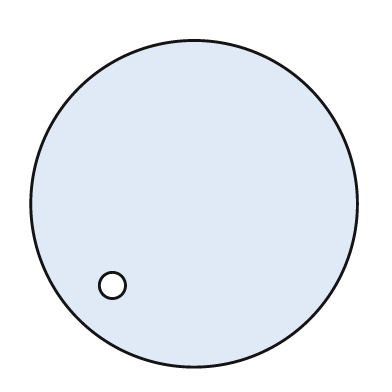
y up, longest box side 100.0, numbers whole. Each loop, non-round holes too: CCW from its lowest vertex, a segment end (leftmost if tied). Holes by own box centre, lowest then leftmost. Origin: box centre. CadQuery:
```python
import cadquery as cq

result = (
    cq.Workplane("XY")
    .moveTo(0.0, 0.0)
    .circle(50.0)
    .moveTo(-25.0, -25.0)
    .circle(4.0)
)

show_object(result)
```